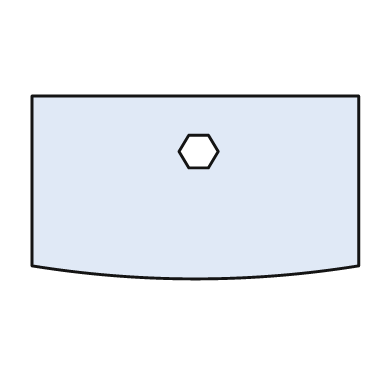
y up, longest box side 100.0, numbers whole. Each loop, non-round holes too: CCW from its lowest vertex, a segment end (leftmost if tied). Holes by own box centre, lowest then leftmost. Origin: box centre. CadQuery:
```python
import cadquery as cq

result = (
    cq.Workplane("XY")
    .moveTo(-50.0, -24.0)
    .threePointArc((0.0, -28.0), (50.0, -24.0))
    .lineTo(50.0, 28.0)
    .lineTo(-50.0, 28.0)
    .close()
    .moveTo(-2.0, 6.0)
    .lineTo(4.0, 6.0)
    .lineTo(7.0, 11.0)
    .lineTo(4.0, 16.0)
    .lineTo(-2.0, 16.0)
    .lineTo(-5.0, 11.0)
    .close()
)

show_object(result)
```